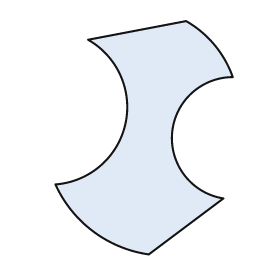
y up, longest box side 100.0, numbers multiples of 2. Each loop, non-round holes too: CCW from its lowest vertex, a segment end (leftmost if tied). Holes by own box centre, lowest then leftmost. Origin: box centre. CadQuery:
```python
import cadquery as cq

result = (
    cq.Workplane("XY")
    .moveTo(2.0, -50.0)
    .lineTo(34.0, -26.0)
    .threePointArc((12.0, 2.0), (38.0, 26.0))
    .threePointArc((30.0, 40.0), (18.0, 50.0))
    .lineTo(-24.0, 42.0)
    .threePointArc((-8.0, 6.0), (-38.0, -20.0))
    .threePointArc((-22.0, -40.0), (2.0, -50.0))
    .close()
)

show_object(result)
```